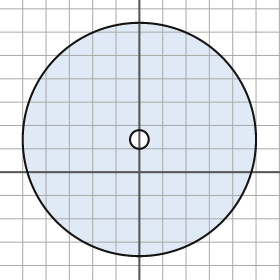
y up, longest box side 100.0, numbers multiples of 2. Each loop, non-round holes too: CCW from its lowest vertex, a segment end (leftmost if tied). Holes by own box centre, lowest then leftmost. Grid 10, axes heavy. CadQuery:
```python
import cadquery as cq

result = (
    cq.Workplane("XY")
    .moveTo(0.0, 14.0)
    .circle(50.0)
    .moveTo(0.0, 14.0)
    .circle(4.0)
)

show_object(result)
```